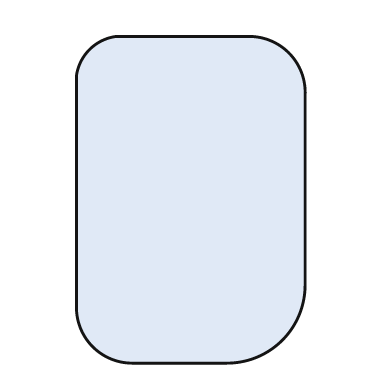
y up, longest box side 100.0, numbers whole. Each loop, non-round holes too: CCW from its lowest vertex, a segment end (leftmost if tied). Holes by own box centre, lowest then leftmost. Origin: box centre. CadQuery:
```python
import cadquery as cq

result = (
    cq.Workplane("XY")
    .moveTo(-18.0, -50.0)
    .lineTo(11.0, -50.0)
    .threePointArc((28.0, -43.0), (35.0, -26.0))
    .lineTo(35.0, 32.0)
    .threePointArc((30.0, 45.0), (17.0, 50.0))
    .lineTo(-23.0, 50.0)
    .threePointArc((-31.0, 46.0), (-35.0, 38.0))
    .lineTo(-35.0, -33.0)
    .threePointArc((-30.0, -45.0), (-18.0, -50.0))
    .close()
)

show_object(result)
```